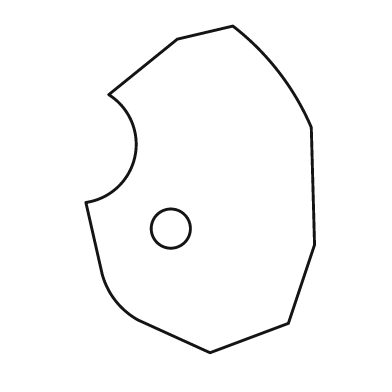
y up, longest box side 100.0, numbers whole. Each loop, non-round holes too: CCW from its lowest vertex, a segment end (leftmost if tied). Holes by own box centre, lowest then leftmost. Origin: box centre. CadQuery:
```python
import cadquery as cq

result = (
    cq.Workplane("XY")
    .moveTo(3.0, -50.0)
    .lineTo(27.0, -41.0)
    .lineTo(35.0, -17.0)
    .lineTo(34.0, 19.0)
    .threePointArc((24.0, 36.0), (10.0, 50.0))
    .lineTo(-7.0, 46.0)
    .lineTo(-28.0, 29.0)
    .threePointArc((-20.0, 10.0), (-35.0, -4.0))
    .lineTo(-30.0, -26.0)
    .threePointArc((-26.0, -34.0), (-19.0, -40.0))
    .close()
    .moveTo(-9.0, -12.0)
    .circle(6.0)
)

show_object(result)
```